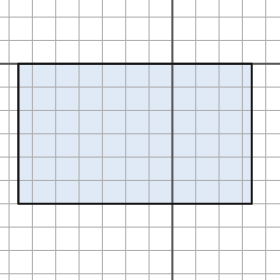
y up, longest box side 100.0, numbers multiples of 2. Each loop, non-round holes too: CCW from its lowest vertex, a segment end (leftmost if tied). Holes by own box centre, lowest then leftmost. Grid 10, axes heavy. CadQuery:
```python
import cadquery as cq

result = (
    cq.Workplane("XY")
    .moveTo(-66.0, -60.0)
    .lineTo(34.0, -60.0)
    .lineTo(34.0, 0.0)
    .lineTo(-66.0, 0.0)
    .close()
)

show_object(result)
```